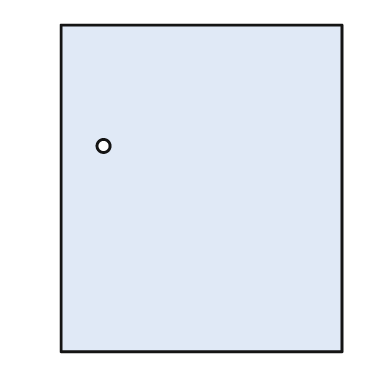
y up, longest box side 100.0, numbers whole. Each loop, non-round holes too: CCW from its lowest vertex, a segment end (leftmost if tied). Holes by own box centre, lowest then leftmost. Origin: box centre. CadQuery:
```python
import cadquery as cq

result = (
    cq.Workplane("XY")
    .moveTo(-43.0, -50.0)
    .lineTo(43.0, -50.0)
    .lineTo(43.0, 50.0)
    .lineTo(-43.0, 50.0)
    .close()
    .moveTo(-30.0, 13.0)
    .circle(2.0)
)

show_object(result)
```